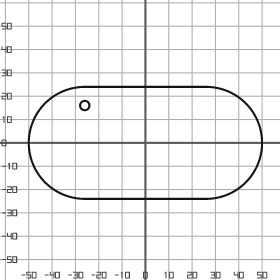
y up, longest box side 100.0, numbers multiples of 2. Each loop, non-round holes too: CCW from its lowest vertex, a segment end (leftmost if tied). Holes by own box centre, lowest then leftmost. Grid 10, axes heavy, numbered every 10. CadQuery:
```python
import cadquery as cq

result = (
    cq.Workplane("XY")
    .moveTo(-26.0, -24.0)
    .lineTo(26.0, -24.0)
    .threePointArc((50.0, 0.0), (26.0, 24.0))
    .lineTo(-26.0, 24.0)
    .threePointArc((-50.0, 0.0), (-26.0, -24.0))
    .close()
    .moveTo(-26.0, 16.0)
    .circle(2.0)
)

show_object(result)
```